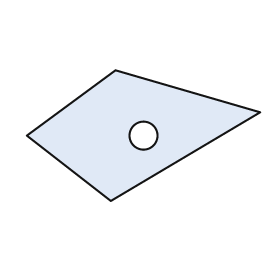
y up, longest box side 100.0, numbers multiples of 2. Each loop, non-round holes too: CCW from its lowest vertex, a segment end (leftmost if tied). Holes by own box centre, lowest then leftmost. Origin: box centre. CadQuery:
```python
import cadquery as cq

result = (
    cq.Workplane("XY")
    .moveTo(-14.0, -28.0)
    .lineTo(50.0, 10.0)
    .lineTo(-12.0, 28.0)
    .lineTo(-50.0, 0.0)
    .close()
    .moveTo(0.0, 0.0)
    .circle(6.0)
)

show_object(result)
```